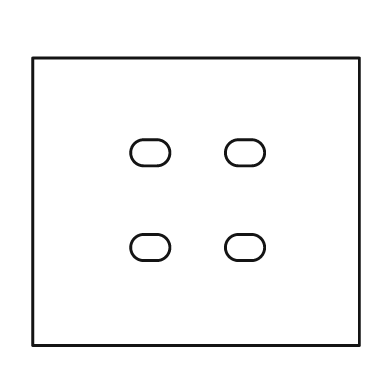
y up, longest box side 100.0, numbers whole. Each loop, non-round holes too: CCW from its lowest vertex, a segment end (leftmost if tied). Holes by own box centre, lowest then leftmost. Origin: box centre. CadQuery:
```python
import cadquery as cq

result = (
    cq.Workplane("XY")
    .moveTo(-50.0, -44.0)
    .lineTo(50.0, -44.0)
    .lineTo(50.0, 44.0)
    .lineTo(-50.0, 44.0)
    .close()
    .moveTo(-16.0, -18.0)
    .lineTo(-12.0, -18.0)
    .threePointArc((-8.0, -14.0), (-12.0, -10.0))
    .lineTo(-16.0, -10.0)
    .threePointArc((-20.0, -14.0), (-16.0, -18.0))
    .close()
    .moveTo(13.0, -18.0)
    .lineTo(17.0, -18.0)
    .threePointArc((21.0, -14.0), (17.0, -10.0))
    .lineTo(13.0, -10.0)
    .threePointArc((9.0, -14.0), (13.0, -18.0))
    .close()
    .moveTo(-16.0, 11.0)
    .lineTo(-12.0, 11.0)
    .threePointArc((-8.0, 15.0), (-12.0, 19.0))
    .lineTo(-16.0, 19.0)
    .threePointArc((-20.0, 15.0), (-16.0, 11.0))
    .close()
    .moveTo(13.0, 11.0)
    .lineTo(17.0, 11.0)
    .threePointArc((21.0, 15.0), (17.0, 19.0))
    .lineTo(13.0, 19.0)
    .threePointArc((9.0, 15.0), (13.0, 11.0))
    .close()
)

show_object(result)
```